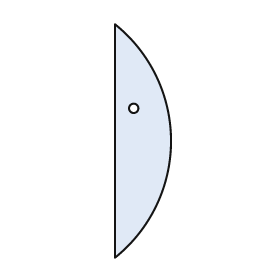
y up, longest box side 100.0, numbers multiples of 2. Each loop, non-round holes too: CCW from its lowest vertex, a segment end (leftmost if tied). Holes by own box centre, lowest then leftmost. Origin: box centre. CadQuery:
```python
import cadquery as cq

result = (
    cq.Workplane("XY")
    .moveTo(-12.0, -50.0)
    .threePointArc((12.0, 0.0), (-12.0, 50.0))
    .close()
    .moveTo(-4.0, 14.0)
    .circle(2.0)
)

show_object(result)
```